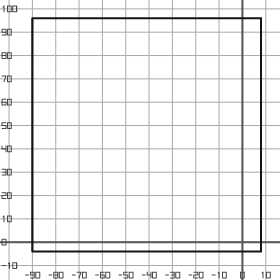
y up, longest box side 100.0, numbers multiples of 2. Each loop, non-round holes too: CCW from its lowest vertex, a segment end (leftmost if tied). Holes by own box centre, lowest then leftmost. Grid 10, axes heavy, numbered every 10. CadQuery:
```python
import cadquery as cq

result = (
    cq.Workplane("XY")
    .moveTo(-90.0, -4.0)
    .lineTo(8.0, -4.0)
    .lineTo(8.0, 96.0)
    .lineTo(-90.0, 96.0)
    .close()
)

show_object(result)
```